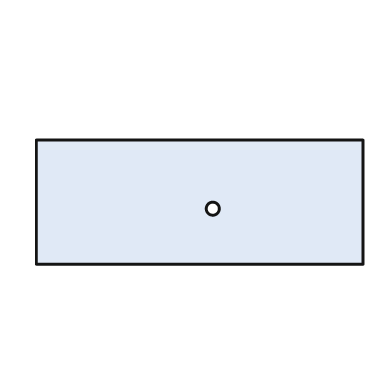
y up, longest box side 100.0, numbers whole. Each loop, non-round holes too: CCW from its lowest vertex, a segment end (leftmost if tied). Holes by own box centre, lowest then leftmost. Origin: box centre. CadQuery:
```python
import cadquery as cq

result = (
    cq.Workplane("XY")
    .moveTo(-50.0, -19.0)
    .lineTo(50.0, -19.0)
    .lineTo(50.0, 19.0)
    .lineTo(-50.0, 19.0)
    .close()
    .moveTo(4.0, -2.0)
    .circle(2.0)
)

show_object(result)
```